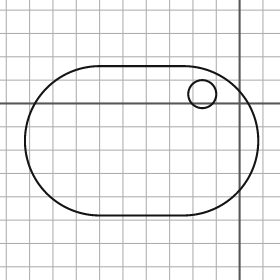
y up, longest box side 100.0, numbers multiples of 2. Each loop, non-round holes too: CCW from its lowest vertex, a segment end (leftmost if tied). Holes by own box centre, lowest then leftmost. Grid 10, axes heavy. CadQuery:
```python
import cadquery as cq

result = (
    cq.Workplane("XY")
    .moveTo(-60.0, -48.0)
    .lineTo(-24.0, -48.0)
    .threePointArc((8.0, -16.0), (-24.0, 16.0))
    .lineTo(-60.0, 16.0)
    .threePointArc((-92.0, -16.0), (-60.0, -48.0))
    .close()
    .moveTo(-16.0, 4.0)
    .circle(6.0)
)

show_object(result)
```